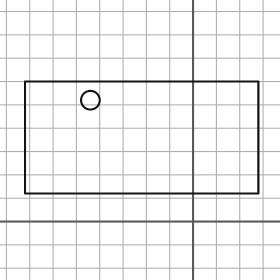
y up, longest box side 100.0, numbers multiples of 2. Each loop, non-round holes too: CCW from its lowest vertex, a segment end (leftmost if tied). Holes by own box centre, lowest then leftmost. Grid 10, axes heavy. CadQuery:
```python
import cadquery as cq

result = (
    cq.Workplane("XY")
    .moveTo(-72.0, 12.0)
    .lineTo(28.0, 12.0)
    .lineTo(28.0, 60.0)
    .lineTo(-72.0, 60.0)
    .close()
    .moveTo(-44.0, 52.0)
    .circle(4.0)
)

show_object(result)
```